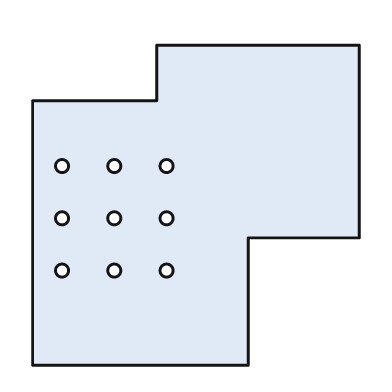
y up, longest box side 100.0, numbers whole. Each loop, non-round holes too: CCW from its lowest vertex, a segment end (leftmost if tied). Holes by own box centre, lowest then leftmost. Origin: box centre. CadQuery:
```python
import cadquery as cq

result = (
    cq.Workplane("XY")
    .moveTo(-50.0, -49.0)
    .lineTo(16.0, -49.0)
    .lineTo(16.0, -10.0)
    .lineTo(50.0, -10.0)
    .lineTo(50.0, 49.0)
    .lineTo(-12.0, 49.0)
    .lineTo(-12.0, 32.0)
    .lineTo(-50.0, 32.0)
    .close()
    .moveTo(-41.0, -20.0)
    .circle(2.0)
    .moveTo(-25.0, -20.0)
    .circle(2.0)
    .moveTo(-9.0, -20.0)
    .circle(2.0)
    .moveTo(-41.0, -4.0)
    .circle(2.0)
    .moveTo(-25.0, -4.0)
    .circle(2.0)
    .moveTo(-9.0, -4.0)
    .circle(2.0)
    .moveTo(-41.0, 12.0)
    .circle(2.0)
    .moveTo(-25.0, 12.0)
    .circle(2.0)
    .moveTo(-9.0, 12.0)
    .circle(2.0)
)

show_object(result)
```